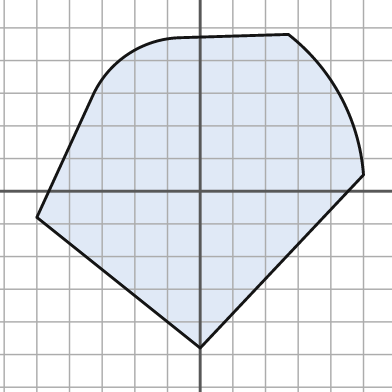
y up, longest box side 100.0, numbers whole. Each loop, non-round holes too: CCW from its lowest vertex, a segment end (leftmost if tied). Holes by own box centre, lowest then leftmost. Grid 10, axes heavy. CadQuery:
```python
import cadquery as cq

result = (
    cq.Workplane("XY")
    .moveTo(0.0, -48.0)
    .lineTo(50.0, 5.0)
    .threePointArc((43.0, 29.0), (27.0, 48.0))
    .lineTo(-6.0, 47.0)
    .threePointArc((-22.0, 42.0), (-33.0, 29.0))
    .lineTo(-50.0, -8.0)
    .close()
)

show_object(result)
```